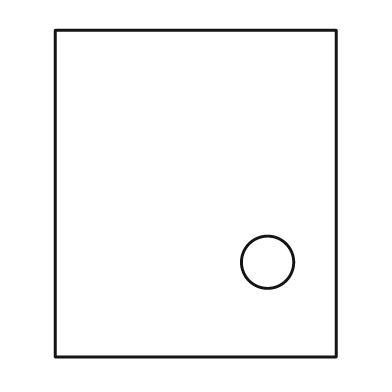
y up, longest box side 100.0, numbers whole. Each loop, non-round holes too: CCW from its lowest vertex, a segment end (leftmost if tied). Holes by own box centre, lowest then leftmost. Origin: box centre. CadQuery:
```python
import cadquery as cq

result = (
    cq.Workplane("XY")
    .moveTo(-43.0, -50.0)
    .lineTo(43.0, -50.0)
    .lineTo(43.0, 50.0)
    .lineTo(-43.0, 50.0)
    .close()
    .moveTo(22.0, -21.0)
    .circle(8.0)
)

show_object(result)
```